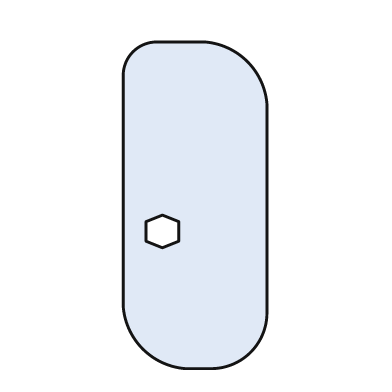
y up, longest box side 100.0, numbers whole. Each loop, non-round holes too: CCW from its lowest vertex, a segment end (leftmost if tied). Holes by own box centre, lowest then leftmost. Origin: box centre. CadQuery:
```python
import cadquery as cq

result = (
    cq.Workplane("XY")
    .moveTo(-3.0, -50.0)
    .lineTo(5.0, -50.0)
    .threePointArc((17.0, -45.0), (22.0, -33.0))
    .lineTo(22.0, 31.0)
    .threePointArc((16.0, 44.0), (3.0, 50.0))
    .lineTo(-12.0, 50.0)
    .threePointArc((-19.0, 47.0), (-22.0, 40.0))
    .lineTo(-22.0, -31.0)
    .threePointArc((-16.0, -44.0), (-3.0, -50.0))
    .close()
    .moveTo(-10.0, -13.0)
    .lineTo(-5.0, -11.0)
    .lineTo(-5.0, -5.0)
    .lineTo(-10.0, -3.0)
    .lineTo(-15.0, -5.0)
    .lineTo(-15.0, -11.0)
    .close()
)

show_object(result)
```